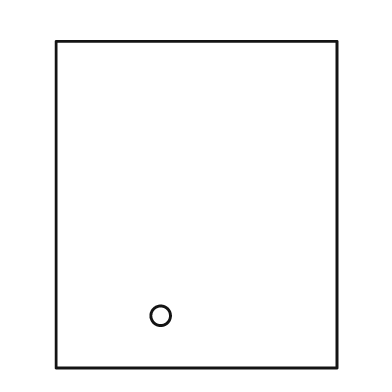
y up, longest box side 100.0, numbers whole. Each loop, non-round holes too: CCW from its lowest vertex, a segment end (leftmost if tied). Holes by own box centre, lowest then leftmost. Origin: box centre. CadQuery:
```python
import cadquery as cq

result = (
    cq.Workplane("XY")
    .moveTo(-43.0, -50.0)
    .lineTo(43.0, -50.0)
    .lineTo(43.0, 50.0)
    .lineTo(-43.0, 50.0)
    .close()
    .moveTo(-11.0, -34.0)
    .circle(3.0)
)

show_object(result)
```